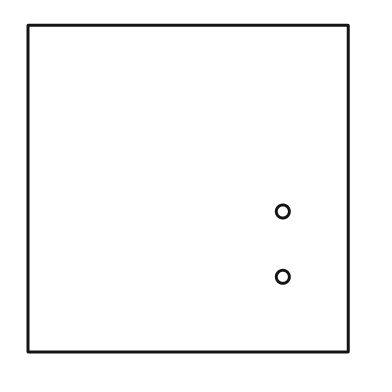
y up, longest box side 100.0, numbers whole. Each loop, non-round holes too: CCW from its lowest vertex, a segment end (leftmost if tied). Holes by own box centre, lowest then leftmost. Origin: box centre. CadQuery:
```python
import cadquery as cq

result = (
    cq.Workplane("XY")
    .moveTo(-49.0, -50.0)
    .lineTo(49.0, -50.0)
    .lineTo(49.0, 50.0)
    .lineTo(-49.0, 50.0)
    .close()
    .moveTo(29.0, -27.0)
    .circle(2.0)
    .moveTo(29.0, -7.0)
    .circle(2.0)
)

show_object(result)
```